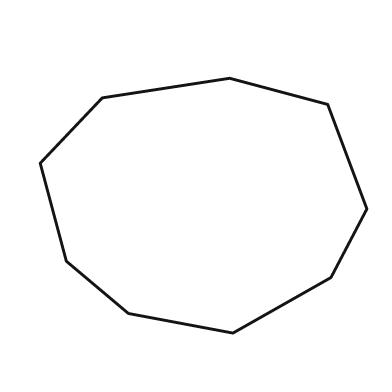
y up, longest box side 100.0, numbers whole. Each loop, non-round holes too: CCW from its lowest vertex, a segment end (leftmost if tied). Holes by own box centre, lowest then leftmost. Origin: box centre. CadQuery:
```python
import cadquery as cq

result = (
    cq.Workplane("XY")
    .moveTo(9.0, -39.0)
    .lineTo(39.0, -22.0)
    .lineTo(50.0, -1.0)
    .lineTo(38.0, 31.0)
    .lineTo(8.0, 39.0)
    .lineTo(-31.0, 33.0)
    .lineTo(-50.0, 13.0)
    .lineTo(-42.0, -17.0)
    .lineTo(-23.0, -33.0)
    .close()
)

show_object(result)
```